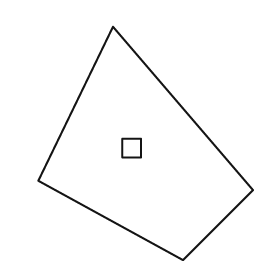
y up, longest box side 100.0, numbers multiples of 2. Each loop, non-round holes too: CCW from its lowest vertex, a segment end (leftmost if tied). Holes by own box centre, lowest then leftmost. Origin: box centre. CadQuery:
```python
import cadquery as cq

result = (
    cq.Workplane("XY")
    .moveTo(16.0, -50.0)
    .lineTo(46.0, -20.0)
    .lineTo(-14.0, 50.0)
    .lineTo(-46.0, -16.0)
    .close()
    .moveTo(-10.0, -6.0)
    .lineTo(-2.0, -6.0)
    .lineTo(-2.0, 2.0)
    .lineTo(-10.0, 2.0)
    .close()
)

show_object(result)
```